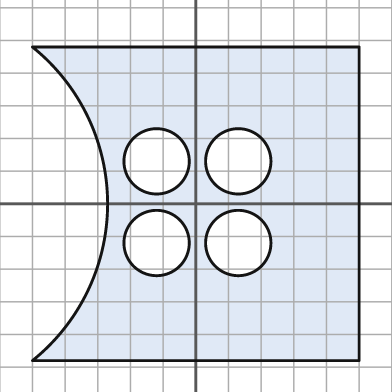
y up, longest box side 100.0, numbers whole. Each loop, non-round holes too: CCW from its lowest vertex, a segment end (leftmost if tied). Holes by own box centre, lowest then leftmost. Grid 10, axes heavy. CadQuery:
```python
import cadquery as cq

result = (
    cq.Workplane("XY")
    .moveTo(-50.0, -48.0)
    .lineTo(50.0, -48.0)
    .lineTo(50.0, 48.0)
    .lineTo(-50.0, 48.0)
    .threePointArc((-27.0, 0.0), (-50.0, -48.0))
    .close()
    .moveTo(-12.0, -12.0)
    .circle(10.0)
    .moveTo(13.0, -12.0)
    .circle(10.0)
    .moveTo(-12.0, 13.0)
    .circle(10.0)
    .moveTo(13.0, 13.0)
    .circle(10.0)
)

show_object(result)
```